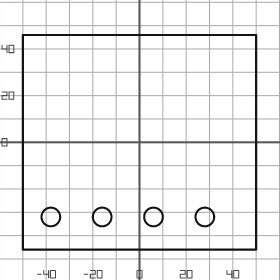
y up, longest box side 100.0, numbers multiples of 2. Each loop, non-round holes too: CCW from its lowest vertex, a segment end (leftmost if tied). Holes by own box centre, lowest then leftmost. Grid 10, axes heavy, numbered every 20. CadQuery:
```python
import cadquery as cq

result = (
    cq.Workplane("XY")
    .moveTo(-50.0, -46.0)
    .lineTo(50.0, -46.0)
    .lineTo(50.0, 46.0)
    .lineTo(-50.0, 46.0)
    .close()
    .moveTo(-38.0, -32.0)
    .circle(4.0)
    .moveTo(-16.0, -32.0)
    .circle(4.0)
    .moveTo(6.0, -32.0)
    .circle(4.0)
    .moveTo(28.0, -32.0)
    .circle(4.0)
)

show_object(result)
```